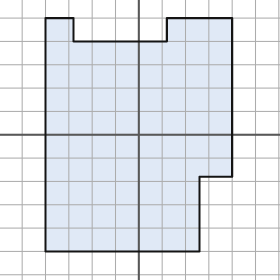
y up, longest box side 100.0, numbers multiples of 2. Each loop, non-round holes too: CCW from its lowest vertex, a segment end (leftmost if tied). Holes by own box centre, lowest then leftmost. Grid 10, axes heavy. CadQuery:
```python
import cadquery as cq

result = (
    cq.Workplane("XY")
    .moveTo(-40.0, -50.0)
    .lineTo(26.0, -50.0)
    .lineTo(26.0, -18.0)
    .lineTo(40.0, -18.0)
    .lineTo(40.0, 50.0)
    .lineTo(12.0, 50.0)
    .lineTo(12.0, 40.0)
    .lineTo(-28.0, 40.0)
    .lineTo(-28.0, 50.0)
    .lineTo(-40.0, 50.0)
    .close()
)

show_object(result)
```